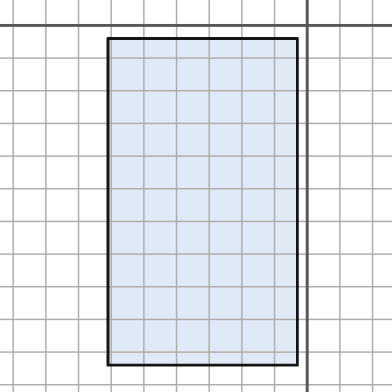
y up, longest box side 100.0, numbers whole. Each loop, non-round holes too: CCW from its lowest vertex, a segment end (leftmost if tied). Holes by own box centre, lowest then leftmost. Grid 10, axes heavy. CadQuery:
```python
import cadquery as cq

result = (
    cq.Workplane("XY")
    .moveTo(-61.0, -104.0)
    .lineTo(-3.0, -104.0)
    .lineTo(-3.0, -4.0)
    .lineTo(-61.0, -4.0)
    .close()
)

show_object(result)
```